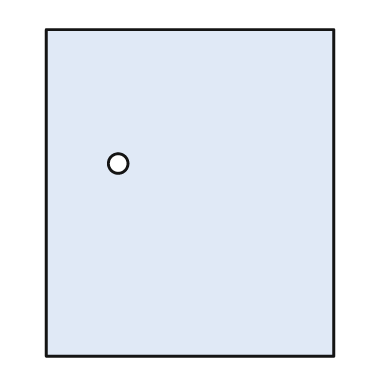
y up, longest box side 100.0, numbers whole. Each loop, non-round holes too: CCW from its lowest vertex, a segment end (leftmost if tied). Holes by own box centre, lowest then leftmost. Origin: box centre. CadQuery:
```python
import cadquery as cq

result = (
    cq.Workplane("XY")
    .moveTo(-44.0, -50.0)
    .lineTo(44.0, -50.0)
    .lineTo(44.0, 50.0)
    .lineTo(-44.0, 50.0)
    .close()
    .moveTo(-22.0, 9.0)
    .circle(3.0)
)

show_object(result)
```